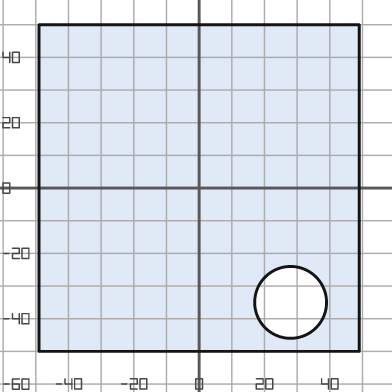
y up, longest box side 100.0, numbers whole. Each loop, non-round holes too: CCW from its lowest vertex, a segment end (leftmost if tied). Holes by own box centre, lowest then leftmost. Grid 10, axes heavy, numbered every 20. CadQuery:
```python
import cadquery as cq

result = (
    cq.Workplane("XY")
    .moveTo(-49.0, -50.0)
    .lineTo(49.0, -50.0)
    .lineTo(49.0, 50.0)
    .lineTo(-49.0, 50.0)
    .close()
    .moveTo(28.0, -35.0)
    .circle(11.0)
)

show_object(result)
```